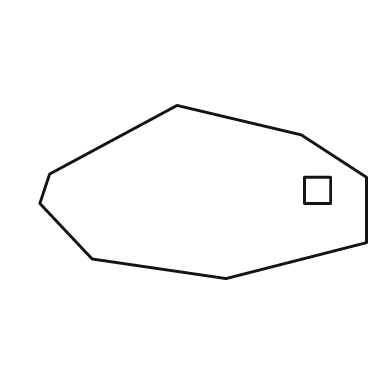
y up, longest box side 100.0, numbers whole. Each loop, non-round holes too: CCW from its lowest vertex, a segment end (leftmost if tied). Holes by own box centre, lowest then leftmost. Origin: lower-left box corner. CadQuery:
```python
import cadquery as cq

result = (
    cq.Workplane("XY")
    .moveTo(57.0, 0.0)
    .lineTo(100.0, 11.0)
    .lineTo(100.0, 31.0)
    .lineTo(80.0, 44.0)
    .lineTo(42.0, 53.0)
    .lineTo(3.0, 32.0)
    .lineTo(0.0, 23.0)
    .lineTo(16.0, 6.0)
    .close()
    .moveTo(81.0, 23.0)
    .lineTo(89.0, 23.0)
    .lineTo(89.0, 31.0)
    .lineTo(81.0, 31.0)
    .close()
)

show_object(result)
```